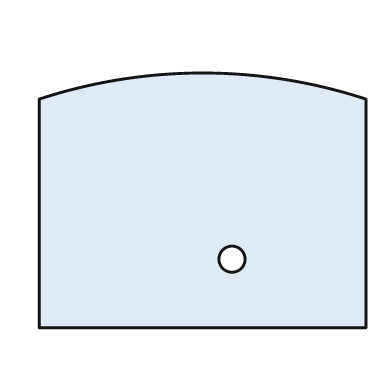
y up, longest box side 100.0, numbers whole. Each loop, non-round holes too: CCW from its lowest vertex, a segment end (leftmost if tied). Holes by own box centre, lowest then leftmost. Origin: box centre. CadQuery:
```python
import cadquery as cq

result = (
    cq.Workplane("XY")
    .moveTo(-50.0, -39.0)
    .lineTo(50.0, -39.0)
    .lineTo(50.0, 31.0)
    .threePointArc((0.0, 39.0), (-50.0, 31.0))
    .close()
    .moveTo(9.0, -18.0)
    .circle(4.0)
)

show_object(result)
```